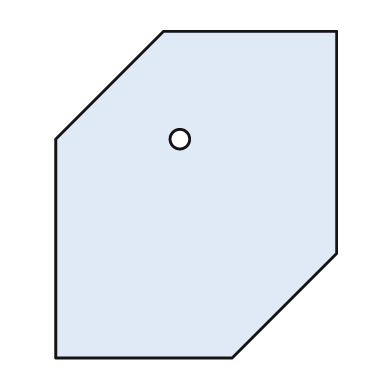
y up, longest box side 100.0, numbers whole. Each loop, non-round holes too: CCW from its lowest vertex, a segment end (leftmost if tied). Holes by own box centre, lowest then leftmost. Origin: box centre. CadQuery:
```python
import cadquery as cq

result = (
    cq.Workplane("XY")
    .moveTo(-43.0, -50.0)
    .lineTo(11.0, -50.0)
    .lineTo(43.0, -18.0)
    .lineTo(43.0, 50.0)
    .lineTo(-10.0, 50.0)
    .lineTo(-43.0, 17.0)
    .close()
    .moveTo(-5.0, 17.0)
    .circle(3.0)
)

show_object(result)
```